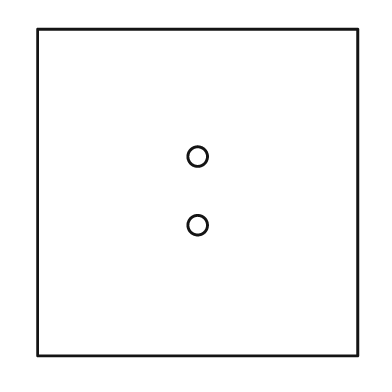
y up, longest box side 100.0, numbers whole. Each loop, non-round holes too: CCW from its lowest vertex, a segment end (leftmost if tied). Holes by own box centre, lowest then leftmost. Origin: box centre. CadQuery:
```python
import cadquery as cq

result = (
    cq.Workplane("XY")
    .moveTo(-49.0, -50.0)
    .lineTo(49.0, -50.0)
    .lineTo(49.0, 50.0)
    .lineTo(-49.0, 50.0)
    .close()
    .moveTo(0.0, -10.0)
    .circle(3.0)
    .moveTo(0.0, 11.0)
    .circle(3.0)
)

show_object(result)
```